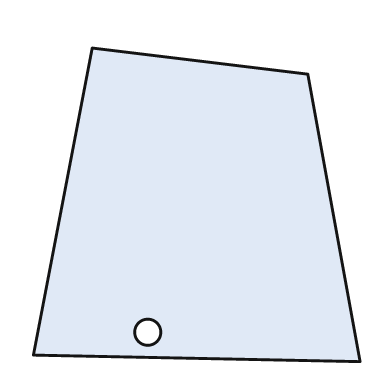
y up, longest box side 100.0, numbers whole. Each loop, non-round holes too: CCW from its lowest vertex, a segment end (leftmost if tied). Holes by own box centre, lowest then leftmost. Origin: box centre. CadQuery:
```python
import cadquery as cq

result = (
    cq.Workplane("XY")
    .moveTo(50.0, -48.0)
    .lineTo(34.0, 40.0)
    .lineTo(-32.0, 48.0)
    .lineTo(-50.0, -46.0)
    .close()
    .moveTo(-15.0, -39.0)
    .circle(4.0)
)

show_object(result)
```